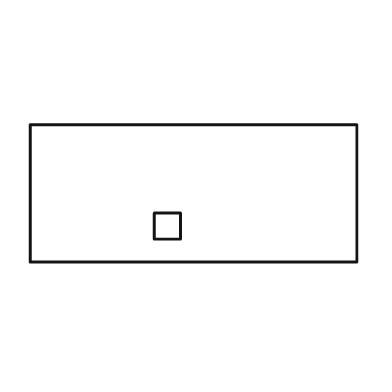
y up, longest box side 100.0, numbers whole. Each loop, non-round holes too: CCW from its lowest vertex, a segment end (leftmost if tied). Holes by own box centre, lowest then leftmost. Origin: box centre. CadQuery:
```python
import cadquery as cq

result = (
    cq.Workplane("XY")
    .moveTo(-50.0, -21.0)
    .lineTo(50.0, -21.0)
    .lineTo(50.0, 21.0)
    .lineTo(-50.0, 21.0)
    .close()
    .moveTo(-12.0, -14.0)
    .lineTo(-4.0, -14.0)
    .lineTo(-4.0, -6.0)
    .lineTo(-12.0, -6.0)
    .close()
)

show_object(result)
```